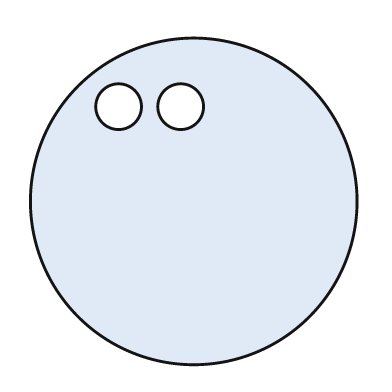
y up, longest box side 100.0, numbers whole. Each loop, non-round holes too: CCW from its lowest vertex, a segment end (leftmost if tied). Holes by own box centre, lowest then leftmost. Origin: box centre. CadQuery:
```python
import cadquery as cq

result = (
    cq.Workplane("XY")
    .moveTo(0.0, 0.0)
    .circle(50.0)
    .moveTo(-23.0, 29.0)
    .circle(7.0)
    .moveTo(-4.0, 29.0)
    .circle(7.0)
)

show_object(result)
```